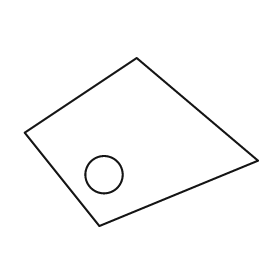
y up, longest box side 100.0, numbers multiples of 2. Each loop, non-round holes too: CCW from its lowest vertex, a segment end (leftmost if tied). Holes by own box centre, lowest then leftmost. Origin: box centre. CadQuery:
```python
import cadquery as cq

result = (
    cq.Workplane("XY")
    .moveTo(-18.0, -36.0)
    .lineTo(50.0, -8.0)
    .lineTo(-2.0, 36.0)
    .lineTo(-50.0, 4.0)
    .close()
    .moveTo(-16.0, -14.0)
    .circle(8.0)
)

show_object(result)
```